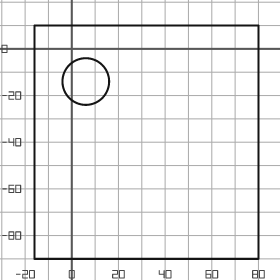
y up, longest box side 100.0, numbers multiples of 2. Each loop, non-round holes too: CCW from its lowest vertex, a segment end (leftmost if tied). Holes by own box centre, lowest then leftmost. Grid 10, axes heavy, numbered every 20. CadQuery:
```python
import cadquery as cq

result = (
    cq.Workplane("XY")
    .moveTo(-16.0, -90.0)
    .lineTo(80.0, -90.0)
    .lineTo(80.0, 10.0)
    .lineTo(-16.0, 10.0)
    .close()
    .moveTo(6.0, -14.0)
    .circle(10.0)
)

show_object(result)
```